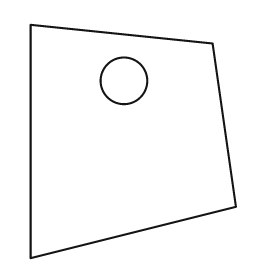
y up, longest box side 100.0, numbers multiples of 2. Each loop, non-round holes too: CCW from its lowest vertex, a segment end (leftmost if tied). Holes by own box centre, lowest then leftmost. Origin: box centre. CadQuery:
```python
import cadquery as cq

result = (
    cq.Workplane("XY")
    .moveTo(-44.0, -50.0)
    .lineTo(44.0, -28.0)
    .lineTo(34.0, 42.0)
    .lineTo(-44.0, 50.0)
    .close()
    .moveTo(-4.0, 26.0)
    .circle(10.0)
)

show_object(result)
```